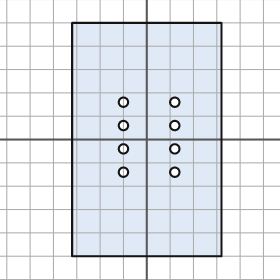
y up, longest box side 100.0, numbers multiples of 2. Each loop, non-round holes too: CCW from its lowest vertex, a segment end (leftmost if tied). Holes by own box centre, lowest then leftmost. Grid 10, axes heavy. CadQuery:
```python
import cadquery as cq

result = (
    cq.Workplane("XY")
    .moveTo(-32.0, -50.0)
    .lineTo(32.0, -50.0)
    .lineTo(32.0, 50.0)
    .lineTo(-32.0, 50.0)
    .close()
    .moveTo(-10.0, -14.0)
    .circle(2.0)
    .moveTo(12.0, -14.0)
    .circle(2.0)
    .moveTo(-10.0, -4.0)
    .circle(2.0)
    .moveTo(12.0, -4.0)
    .circle(2.0)
    .moveTo(-10.0, 6.0)
    .circle(2.0)
    .moveTo(12.0, 6.0)
    .circle(2.0)
    .moveTo(-10.0, 16.0)
    .circle(2.0)
    .moveTo(12.0, 16.0)
    .circle(2.0)
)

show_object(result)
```